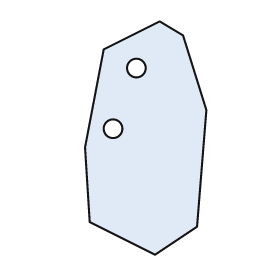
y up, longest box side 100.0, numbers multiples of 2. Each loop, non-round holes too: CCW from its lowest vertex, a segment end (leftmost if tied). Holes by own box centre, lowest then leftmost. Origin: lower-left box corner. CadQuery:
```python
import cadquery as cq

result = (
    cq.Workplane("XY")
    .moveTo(30.0, 0.0)
    .lineTo(48.0, 12.0)
    .lineTo(52.0, 62.0)
    .lineTo(42.0, 94.0)
    .lineTo(32.0, 100.0)
    .lineTo(8.0, 88.0)
    .lineTo(0.0, 46.0)
    .lineTo(2.0, 14.0)
    .close()
    .moveTo(12.0, 54.0)
    .circle(4.0)
    .moveTo(22.0, 80.0)
    .circle(4.0)
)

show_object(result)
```